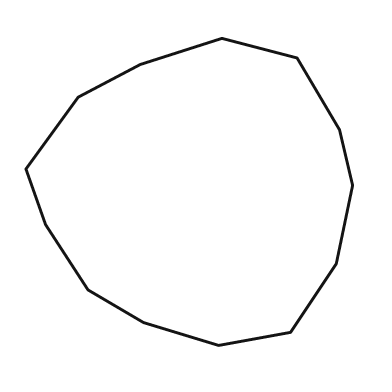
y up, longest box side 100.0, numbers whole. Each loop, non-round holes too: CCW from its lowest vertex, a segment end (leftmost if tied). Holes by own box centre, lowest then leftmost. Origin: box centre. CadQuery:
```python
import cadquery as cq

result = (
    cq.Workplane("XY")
    .moveTo(9.0, -47.0)
    .lineTo(31.0, -43.0)
    .lineTo(45.0, -22.0)
    .lineTo(50.0, 2.0)
    .lineTo(46.0, 19.0)
    .lineTo(33.0, 41.0)
    .lineTo(10.0, 47.0)
    .lineTo(-15.0, 39.0)
    .lineTo(-34.0, 29.0)
    .lineTo(-50.0, 7.0)
    .lineTo(-44.0, -10.0)
    .lineTo(-31.0, -30.0)
    .lineTo(-14.0, -40.0)
    .close()
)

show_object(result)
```